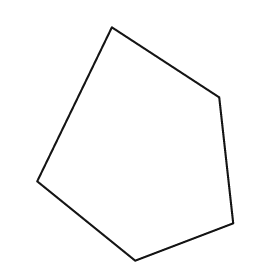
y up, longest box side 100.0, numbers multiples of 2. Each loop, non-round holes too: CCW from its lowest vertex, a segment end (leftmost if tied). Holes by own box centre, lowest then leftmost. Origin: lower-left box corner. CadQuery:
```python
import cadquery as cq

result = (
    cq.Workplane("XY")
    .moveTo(42.0, 0.0)
    .lineTo(84.0, 16.0)
    .lineTo(78.0, 70.0)
    .lineTo(32.0, 100.0)
    .lineTo(0.0, 34.0)
    .close()
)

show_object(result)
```